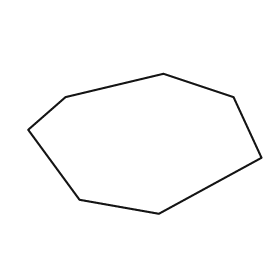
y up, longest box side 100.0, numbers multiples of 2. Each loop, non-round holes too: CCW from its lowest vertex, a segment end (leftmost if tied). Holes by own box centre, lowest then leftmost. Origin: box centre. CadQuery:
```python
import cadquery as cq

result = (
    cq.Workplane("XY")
    .moveTo(6.0, -30.0)
    .lineTo(50.0, -6.0)
    .lineTo(38.0, 20.0)
    .lineTo(8.0, 30.0)
    .lineTo(-34.0, 20.0)
    .lineTo(-50.0, 6.0)
    .lineTo(-28.0, -24.0)
    .close()
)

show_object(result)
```